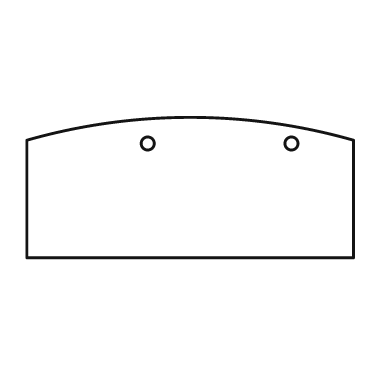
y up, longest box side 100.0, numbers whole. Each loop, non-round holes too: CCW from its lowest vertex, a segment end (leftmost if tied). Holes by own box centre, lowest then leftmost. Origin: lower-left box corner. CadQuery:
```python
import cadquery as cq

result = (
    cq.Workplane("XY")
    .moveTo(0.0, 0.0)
    .lineTo(100.0, 0.0)
    .lineTo(100.0, 36.0)
    .threePointArc((50.0, 43.0), (0.0, 36.0))
    .close()
    .moveTo(37.0, 35.0)
    .circle(2.0)
    .moveTo(81.0, 35.0)
    .circle(2.0)
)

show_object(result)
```